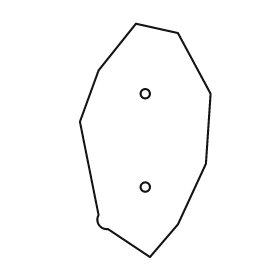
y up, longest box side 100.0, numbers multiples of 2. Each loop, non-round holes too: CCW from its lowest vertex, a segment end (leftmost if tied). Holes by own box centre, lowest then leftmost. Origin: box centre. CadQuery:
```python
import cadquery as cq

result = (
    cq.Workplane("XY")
    .moveTo(2.0, -50.0)
    .lineTo(14.0, -36.0)
    .lineTo(26.0, -10.0)
    .lineTo(28.0, 20.0)
    .lineTo(14.0, 46.0)
    .lineTo(-4.0, 50.0)
    .lineTo(-20.0, 30.0)
    .lineTo(-28.0, 8.0)
    .lineTo(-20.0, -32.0)
    .threePointArc((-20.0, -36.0), (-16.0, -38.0))
    .close()
    .moveTo(0.0, -20.0)
    .circle(2.0)
    .moveTo(0.0, 20.0)
    .circle(2.0)
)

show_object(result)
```